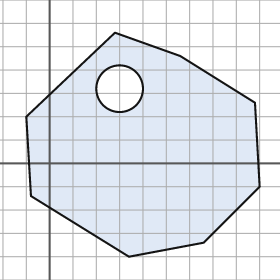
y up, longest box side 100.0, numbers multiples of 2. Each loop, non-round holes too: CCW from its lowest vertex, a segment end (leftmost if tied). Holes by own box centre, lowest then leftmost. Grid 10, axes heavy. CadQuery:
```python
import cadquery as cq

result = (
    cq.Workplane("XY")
    .moveTo(34.0, -40.0)
    .lineTo(66.0, -34.0)
    .lineTo(90.0, -10.0)
    .lineTo(88.0, 26.0)
    .lineTo(56.0, 46.0)
    .lineTo(28.0, 56.0)
    .lineTo(-10.0, 20.0)
    .lineTo(-8.0, -14.0)
    .close()
    .moveTo(30.0, 32.0)
    .circle(10.0)
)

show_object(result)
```